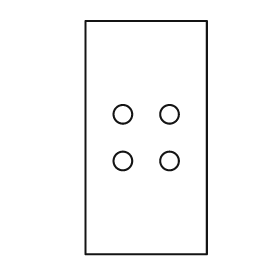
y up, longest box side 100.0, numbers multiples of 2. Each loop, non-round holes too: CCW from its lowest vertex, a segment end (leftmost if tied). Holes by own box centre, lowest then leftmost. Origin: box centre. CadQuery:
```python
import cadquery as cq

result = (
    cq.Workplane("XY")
    .moveTo(-26.0, -50.0)
    .lineTo(26.0, -50.0)
    .lineTo(26.0, 50.0)
    .lineTo(-26.0, 50.0)
    .close()
    .moveTo(-10.0, -10.0)
    .circle(4.0)
    .moveTo(10.0, -10.0)
    .circle(4.0)
    .moveTo(-10.0, 10.0)
    .circle(4.0)
    .moveTo(10.0, 10.0)
    .circle(4.0)
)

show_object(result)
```